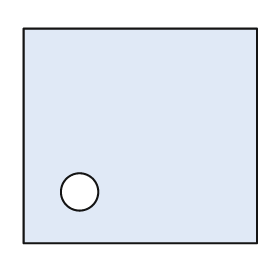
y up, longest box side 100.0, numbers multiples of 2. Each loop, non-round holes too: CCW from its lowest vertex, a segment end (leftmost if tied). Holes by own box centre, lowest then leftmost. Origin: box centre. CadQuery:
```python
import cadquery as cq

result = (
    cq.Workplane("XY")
    .moveTo(-50.0, -46.0)
    .lineTo(50.0, -46.0)
    .lineTo(50.0, 46.0)
    .lineTo(-50.0, 46.0)
    .close()
    .moveTo(-26.0, -24.0)
    .circle(8.0)
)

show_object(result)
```